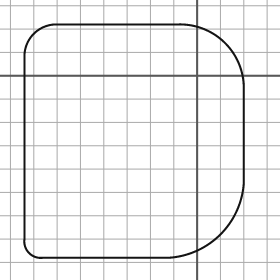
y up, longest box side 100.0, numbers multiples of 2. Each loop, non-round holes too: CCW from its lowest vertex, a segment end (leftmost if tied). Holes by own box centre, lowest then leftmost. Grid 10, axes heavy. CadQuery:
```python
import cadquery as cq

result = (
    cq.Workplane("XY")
    .moveTo(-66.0, -78.0)
    .lineTo(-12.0, -78.0)
    .threePointArc((10.0, -68.0), (20.0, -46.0))
    .lineTo(20.0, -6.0)
    .threePointArc((12.0, 14.0), (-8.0, 22.0))
    .lineTo(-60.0, 22.0)
    .threePointArc((-70.0, 18.0), (-74.0, 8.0))
    .lineTo(-74.0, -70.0)
    .threePointArc((-72.0, -76.0), (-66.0, -78.0))
    .close()
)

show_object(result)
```